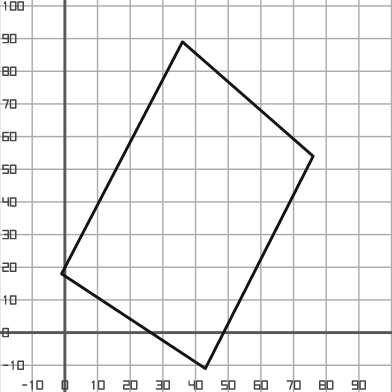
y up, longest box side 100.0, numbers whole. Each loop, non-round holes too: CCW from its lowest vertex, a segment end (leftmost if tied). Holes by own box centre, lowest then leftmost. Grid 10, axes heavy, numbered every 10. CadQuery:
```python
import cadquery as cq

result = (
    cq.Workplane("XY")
    .moveTo(43.0, -11.0)
    .lineTo(76.0, 54.0)
    .lineTo(36.0, 89.0)
    .lineTo(-1.0, 18.0)
    .close()
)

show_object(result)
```